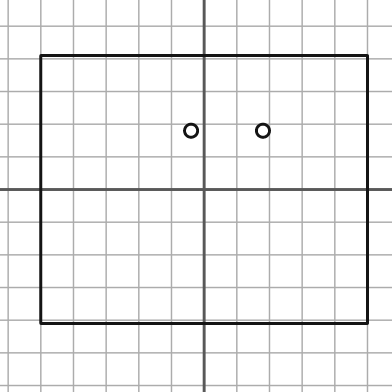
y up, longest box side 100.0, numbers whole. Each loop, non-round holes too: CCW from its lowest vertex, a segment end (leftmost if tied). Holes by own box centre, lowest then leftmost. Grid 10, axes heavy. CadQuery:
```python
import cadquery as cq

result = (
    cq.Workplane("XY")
    .moveTo(-50.0, -41.0)
    .lineTo(50.0, -41.0)
    .lineTo(50.0, 41.0)
    .lineTo(-50.0, 41.0)
    .close()
    .moveTo(-4.0, 18.0)
    .circle(2.0)
    .moveTo(18.0, 18.0)
    .circle(2.0)
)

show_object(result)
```